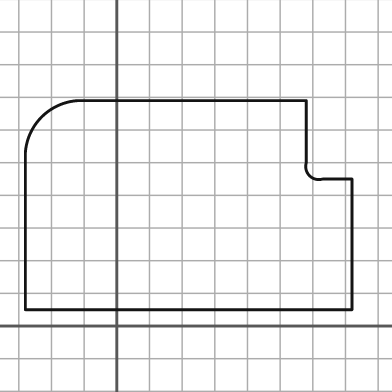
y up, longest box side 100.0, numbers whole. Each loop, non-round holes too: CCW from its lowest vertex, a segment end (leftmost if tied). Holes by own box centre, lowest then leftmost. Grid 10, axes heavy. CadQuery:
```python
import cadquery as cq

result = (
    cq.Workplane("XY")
    .moveTo(-28.0, 5.0)
    .lineTo(72.0, 5.0)
    .lineTo(72.0, 45.0)
    .lineTo(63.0, 45.0)
    .threePointArc((59.0, 46.0), (58.0, 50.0))
    .lineTo(58.0, 69.0)
    .lineTo(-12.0, 69.0)
    .threePointArc((-23.0, 64.0), (-28.0, 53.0))
    .close()
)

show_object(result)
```